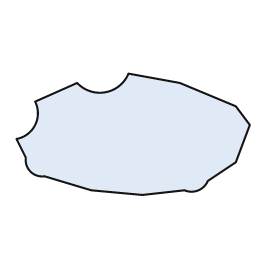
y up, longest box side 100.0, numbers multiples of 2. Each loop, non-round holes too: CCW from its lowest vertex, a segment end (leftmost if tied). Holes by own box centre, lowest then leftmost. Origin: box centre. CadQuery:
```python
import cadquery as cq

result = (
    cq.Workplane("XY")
    .moveTo(4.0, -26.0)
    .lineTo(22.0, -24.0)
    .threePointArc((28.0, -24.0), (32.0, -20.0))
    .lineTo(44.0, -12.0)
    .lineTo(50.0, 4.0)
    .lineTo(44.0, 12.0)
    .lineTo(20.0, 22.0)
    .lineTo(-2.0, 26.0)
    .threePointArc((-12.0, 18.0), (-24.0, 22.0))
    .lineTo(-42.0, 14.0)
    .threePointArc((-42.0, 4.0), (-50.0, -2.0))
    .lineTo(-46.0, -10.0)
    .threePointArc((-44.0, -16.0), (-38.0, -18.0))
    .lineTo(-18.0, -24.0)
    .close()
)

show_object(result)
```